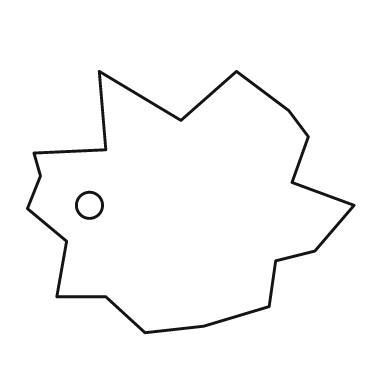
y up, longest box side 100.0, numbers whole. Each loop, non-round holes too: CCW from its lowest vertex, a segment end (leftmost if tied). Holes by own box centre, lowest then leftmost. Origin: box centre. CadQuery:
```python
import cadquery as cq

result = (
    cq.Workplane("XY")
    .moveTo(-14.0, -40.0)
    .lineTo(4.0, -38.0)
    .lineTo(24.0, -32.0)
    .lineTo(26.0, -18.0)
    .lineTo(38.0, -15.0)
    .lineTo(50.0, -1.0)
    .lineTo(31.0, 6.0)
    .lineTo(36.0, 20.0)
    .lineTo(30.0, 28.0)
    .lineTo(14.0, 40.0)
    .lineTo(-3.0, 25.0)
    .lineTo(-28.0, 40.0)
    .lineTo(-26.0, 16.0)
    .lineTo(-48.0, 15.0)
    .lineTo(-46.0, 8.0)
    .lineTo(-50.0, -2.0)
    .lineTo(-38.0, -12.0)
    .lineTo(-41.0, -29.0)
    .lineTo(-26.0, -29.0)
    .close()
    .moveTo(-31.0, -1.0)
    .circle(4.0)
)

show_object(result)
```